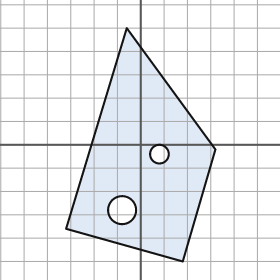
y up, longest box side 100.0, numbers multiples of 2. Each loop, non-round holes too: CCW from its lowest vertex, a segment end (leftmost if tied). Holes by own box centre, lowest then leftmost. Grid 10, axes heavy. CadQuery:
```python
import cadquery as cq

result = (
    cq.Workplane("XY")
    .moveTo(18.0, -50.0)
    .lineTo(32.0, -2.0)
    .lineTo(-6.0, 50.0)
    .lineTo(-32.0, -36.0)
    .close()
    .moveTo(-8.0, -28.0)
    .circle(6.0)
    .moveTo(8.0, -4.0)
    .circle(4.0)
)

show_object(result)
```